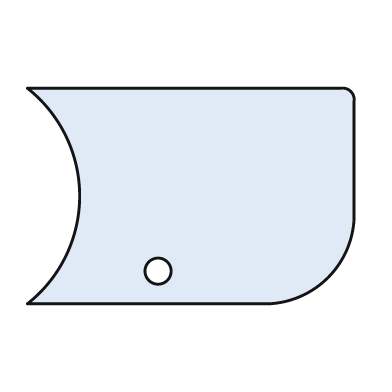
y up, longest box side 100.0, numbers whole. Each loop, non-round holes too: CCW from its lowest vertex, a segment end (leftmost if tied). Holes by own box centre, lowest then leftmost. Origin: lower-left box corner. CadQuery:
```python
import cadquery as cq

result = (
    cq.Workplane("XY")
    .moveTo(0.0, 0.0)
    .lineTo(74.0, 0.0)
    .threePointArc((92.0, 8.0), (100.0, 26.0))
    .lineTo(100.0, 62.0)
    .threePointArc((99.0, 65.0), (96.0, 66.0))
    .lineTo(0.0, 66.0)
    .threePointArc((16.0, 33.0), (0.0, 0.0))
    .close()
    .moveTo(40.0, 10.0)
    .circle(4.0)
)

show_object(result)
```